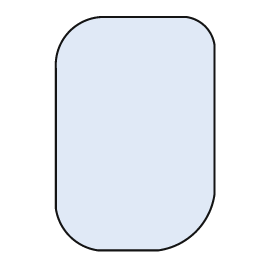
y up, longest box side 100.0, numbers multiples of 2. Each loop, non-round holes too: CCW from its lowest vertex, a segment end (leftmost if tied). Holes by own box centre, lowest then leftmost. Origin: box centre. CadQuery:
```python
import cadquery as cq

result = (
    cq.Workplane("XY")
    .moveTo(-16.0, -50.0)
    .lineTo(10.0, -50.0)
    .threePointArc((26.0, -42.0), (34.0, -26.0))
    .lineTo(34.0, 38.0)
    .threePointArc((30.0, 46.0), (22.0, 50.0))
    .lineTo(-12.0, 50.0)
    .threePointArc((-28.0, 44.0), (-34.0, 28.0))
    .lineTo(-34.0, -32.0)
    .threePointArc((-28.0, -44.0), (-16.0, -50.0))
    .close()
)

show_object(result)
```